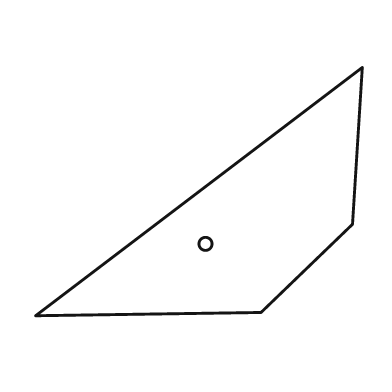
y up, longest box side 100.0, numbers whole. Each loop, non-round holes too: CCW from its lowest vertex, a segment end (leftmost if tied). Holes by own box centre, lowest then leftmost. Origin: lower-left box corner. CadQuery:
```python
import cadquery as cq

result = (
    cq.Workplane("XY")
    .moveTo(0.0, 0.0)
    .lineTo(69.0, 1.0)
    .lineTo(97.0, 28.0)
    .lineTo(100.0, 76.0)
    .close()
    .moveTo(52.0, 22.0)
    .circle(2.0)
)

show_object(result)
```